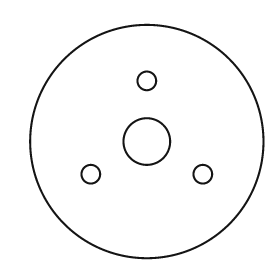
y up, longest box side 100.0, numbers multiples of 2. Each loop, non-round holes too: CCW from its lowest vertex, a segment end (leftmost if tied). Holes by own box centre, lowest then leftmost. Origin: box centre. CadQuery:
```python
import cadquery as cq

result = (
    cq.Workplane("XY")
    .moveTo(0.0, 0.0)
    .circle(50.0)
    .moveTo(-24.0, -14.0)
    .circle(4.0)
    .moveTo(24.0, -14.0)
    .circle(4.0)
    .moveTo(0.0, 0.0)
    .circle(10.0)
    .moveTo(0.0, 26.0)
    .circle(4.0)
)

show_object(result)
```